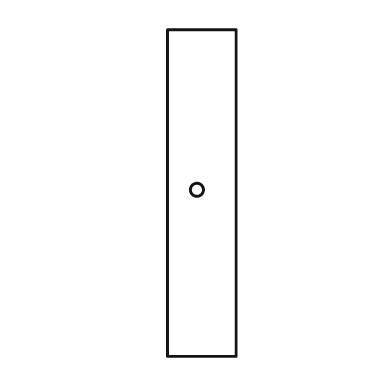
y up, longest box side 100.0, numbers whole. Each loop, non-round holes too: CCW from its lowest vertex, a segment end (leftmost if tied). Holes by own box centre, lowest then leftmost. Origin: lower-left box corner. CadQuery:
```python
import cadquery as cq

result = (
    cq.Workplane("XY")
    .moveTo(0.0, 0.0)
    .lineTo(21.0, 0.0)
    .lineTo(21.0, 100.0)
    .lineTo(0.0, 100.0)
    .close()
    .moveTo(9.0, 51.0)
    .circle(2.0)
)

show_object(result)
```